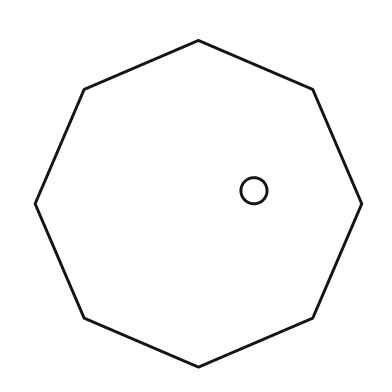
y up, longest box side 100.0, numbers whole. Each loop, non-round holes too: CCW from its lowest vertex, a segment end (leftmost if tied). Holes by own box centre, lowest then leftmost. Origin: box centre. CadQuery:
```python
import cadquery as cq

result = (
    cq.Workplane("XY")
    .moveTo(0.0, -50.0)
    .lineTo(35.0, -35.0)
    .lineTo(50.0, 0.0)
    .lineTo(35.0, 35.0)
    .lineTo(0.0, 50.0)
    .lineTo(-35.0, 35.0)
    .lineTo(-50.0, 0.0)
    .lineTo(-35.0, -35.0)
    .close()
    .moveTo(17.0, 4.0)
    .circle(4.0)
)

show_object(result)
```